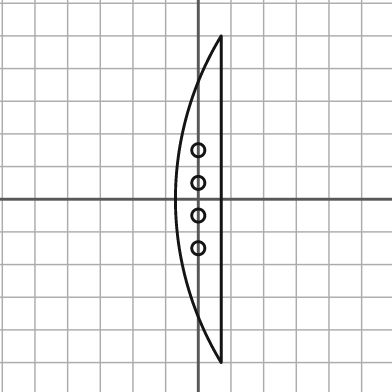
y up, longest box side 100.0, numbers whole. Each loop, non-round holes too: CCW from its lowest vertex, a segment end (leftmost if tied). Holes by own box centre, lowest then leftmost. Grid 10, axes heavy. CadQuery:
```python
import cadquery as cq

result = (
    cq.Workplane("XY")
    .moveTo(7.0, -50.0)
    .lineTo(7.0, 50.0)
    .threePointArc((-7.0, 0.0), (7.0, -50.0))
    .close()
    .moveTo(0.0, -15.0)
    .circle(2.0)
    .moveTo(0.0, -5.0)
    .circle(2.0)
    .moveTo(0.0, 5.0)
    .circle(2.0)
    .moveTo(0.0, 15.0)
    .circle(2.0)
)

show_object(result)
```